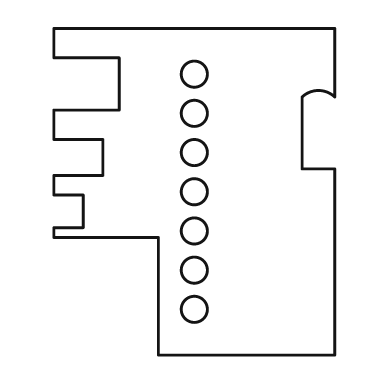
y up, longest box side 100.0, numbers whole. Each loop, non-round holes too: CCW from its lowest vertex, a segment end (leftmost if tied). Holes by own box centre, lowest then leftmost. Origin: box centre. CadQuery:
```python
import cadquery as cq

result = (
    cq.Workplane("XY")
    .moveTo(-11.0, -50.0)
    .lineTo(43.0, -50.0)
    .lineTo(43.0, 7.0)
    .lineTo(33.0, 7.0)
    .lineTo(33.0, 29.0)
    .threePointArc((38.0, 31.0), (43.0, 29.0))
    .lineTo(43.0, 50.0)
    .lineTo(-43.0, 50.0)
    .lineTo(-43.0, 41.0)
    .lineTo(-23.0, 41.0)
    .lineTo(-23.0, 25.0)
    .lineTo(-43.0, 25.0)
    .lineTo(-43.0, 16.0)
    .lineTo(-28.0, 16.0)
    .lineTo(-28.0, 5.0)
    .lineTo(-43.0, 5.0)
    .lineTo(-43.0, -1.0)
    .lineTo(-34.0, -1.0)
    .lineTo(-34.0, -11.0)
    .lineTo(-43.0, -11.0)
    .lineTo(-43.0, -14.0)
    .lineTo(-11.0, -14.0)
    .close()
    .moveTo(0.0, -36.0)
    .circle(4.0)
    .moveTo(0.0, -24.0)
    .circle(4.0)
    .moveTo(0.0, -12.0)
    .circle(4.0)
    .moveTo(0.0, 0.0)
    .circle(4.0)
    .moveTo(0.0, 12.0)
    .circle(4.0)
    .moveTo(0.0, 24.0)
    .circle(4.0)
    .moveTo(0.0, 36.0)
    .circle(4.0)
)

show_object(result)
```